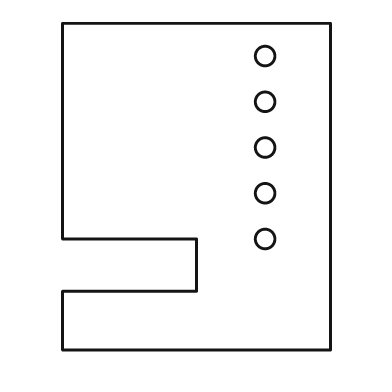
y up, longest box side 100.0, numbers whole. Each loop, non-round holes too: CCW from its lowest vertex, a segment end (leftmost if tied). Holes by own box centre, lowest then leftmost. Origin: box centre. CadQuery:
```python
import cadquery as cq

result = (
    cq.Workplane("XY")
    .moveTo(-41.0, -50.0)
    .lineTo(41.0, -50.0)
    .lineTo(41.0, 50.0)
    .lineTo(-41.0, 50.0)
    .lineTo(-41.0, -16.0)
    .lineTo(0.0, -16.0)
    .lineTo(0.0, -32.0)
    .lineTo(-41.0, -32.0)
    .close()
    .moveTo(21.0, -16.0)
    .circle(3.0)
    .moveTo(21.0, -2.0)
    .circle(3.0)
    .moveTo(21.0, 12.0)
    .circle(3.0)
    .moveTo(21.0, 26.0)
    .circle(3.0)
    .moveTo(21.0, 40.0)
    .circle(3.0)
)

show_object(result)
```